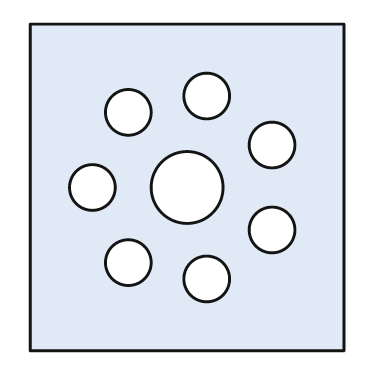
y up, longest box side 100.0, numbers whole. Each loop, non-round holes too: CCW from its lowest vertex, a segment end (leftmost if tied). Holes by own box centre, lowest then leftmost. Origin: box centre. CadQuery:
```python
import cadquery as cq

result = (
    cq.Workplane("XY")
    .moveTo(-48.0, -50.0)
    .lineTo(48.0, -50.0)
    .lineTo(48.0, 50.0)
    .lineTo(-48.0, 50.0)
    .close()
    .moveTo(6.0, -28.0)
    .circle(7.0)
    .moveTo(-18.0, -23.0)
    .circle(7.0)
    .moveTo(26.0, -13.0)
    .circle(7.0)
    .moveTo(-29.0, 0.0)
    .circle(7.0)
    .moveTo(0.0, 0.0)
    .circle(11.0)
    .moveTo(26.0, 13.0)
    .circle(7.0)
    .moveTo(-18.0, 23.0)
    .circle(7.0)
    .moveTo(6.0, 28.0)
    .circle(7.0)
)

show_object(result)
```